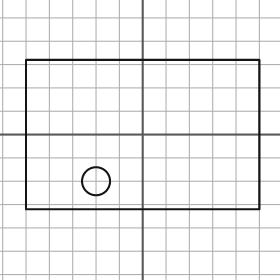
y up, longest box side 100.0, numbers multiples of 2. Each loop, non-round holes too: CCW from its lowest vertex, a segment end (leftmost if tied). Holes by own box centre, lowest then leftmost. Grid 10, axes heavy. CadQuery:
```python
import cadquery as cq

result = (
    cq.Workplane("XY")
    .moveTo(-50.0, -32.0)
    .lineTo(50.0, -32.0)
    .lineTo(50.0, 32.0)
    .lineTo(-50.0, 32.0)
    .close()
    .moveTo(-20.0, -20.0)
    .circle(6.0)
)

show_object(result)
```